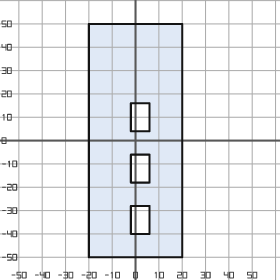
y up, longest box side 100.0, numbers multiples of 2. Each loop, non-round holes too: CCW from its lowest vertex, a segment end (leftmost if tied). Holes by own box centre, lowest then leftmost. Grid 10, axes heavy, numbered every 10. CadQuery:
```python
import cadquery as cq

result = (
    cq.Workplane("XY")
    .moveTo(-20.0, -50.0)
    .lineTo(20.0, -50.0)
    .lineTo(20.0, 50.0)
    .lineTo(-20.0, 50.0)
    .close()
    .moveTo(-2.0, -40.0)
    .lineTo(6.0, -40.0)
    .lineTo(6.0, -28.0)
    .lineTo(-2.0, -28.0)
    .close()
    .moveTo(-2.0, -18.0)
    .lineTo(6.0, -18.0)
    .lineTo(6.0, -6.0)
    .lineTo(-2.0, -6.0)
    .close()
    .moveTo(-2.0, 4.0)
    .lineTo(6.0, 4.0)
    .lineTo(6.0, 16.0)
    .lineTo(-2.0, 16.0)
    .close()
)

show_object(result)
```